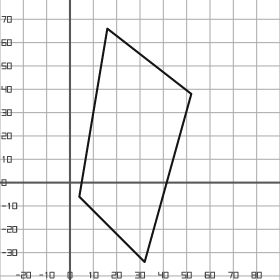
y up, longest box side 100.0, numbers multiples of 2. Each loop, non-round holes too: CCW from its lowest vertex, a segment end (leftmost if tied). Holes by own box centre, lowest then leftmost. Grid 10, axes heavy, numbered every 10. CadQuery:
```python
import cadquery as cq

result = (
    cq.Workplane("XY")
    .moveTo(32.0, -34.0)
    .lineTo(52.0, 38.0)
    .lineTo(16.0, 66.0)
    .lineTo(4.0, -6.0)
    .close()
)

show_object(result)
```